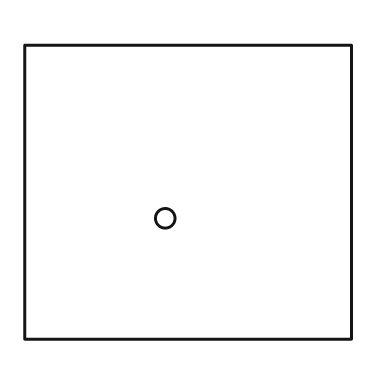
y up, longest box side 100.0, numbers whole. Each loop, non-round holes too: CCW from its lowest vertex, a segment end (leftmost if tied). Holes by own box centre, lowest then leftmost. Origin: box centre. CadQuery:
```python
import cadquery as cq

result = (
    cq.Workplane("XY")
    .moveTo(-50.0, -45.0)
    .lineTo(50.0, -45.0)
    .lineTo(50.0, 45.0)
    .lineTo(-50.0, 45.0)
    .close()
    .moveTo(-7.0, -8.0)
    .circle(3.0)
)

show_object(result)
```